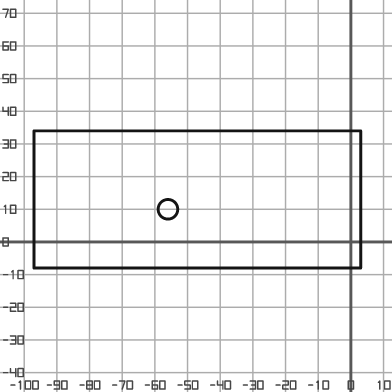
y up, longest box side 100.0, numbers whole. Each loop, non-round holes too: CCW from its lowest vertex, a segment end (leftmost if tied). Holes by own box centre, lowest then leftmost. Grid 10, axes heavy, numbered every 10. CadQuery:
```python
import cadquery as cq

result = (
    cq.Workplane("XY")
    .moveTo(-97.0, -8.0)
    .lineTo(3.0, -8.0)
    .lineTo(3.0, 34.0)
    .lineTo(-97.0, 34.0)
    .close()
    .moveTo(-56.0, 10.0)
    .circle(3.0)
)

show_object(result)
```